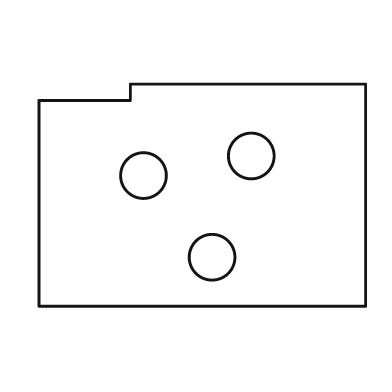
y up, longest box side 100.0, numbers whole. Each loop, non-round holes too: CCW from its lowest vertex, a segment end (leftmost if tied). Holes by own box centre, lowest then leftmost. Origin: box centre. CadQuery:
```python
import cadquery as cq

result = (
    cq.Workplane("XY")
    .moveTo(-50.0, -34.0)
    .lineTo(50.0, -34.0)
    .lineTo(50.0, 34.0)
    .lineTo(-22.0, 34.0)
    .lineTo(-22.0, 29.0)
    .lineTo(-50.0, 29.0)
    .close()
    .moveTo(3.0, -19.0)
    .circle(7.0)
    .moveTo(-18.0, 6.0)
    .circle(7.0)
    .moveTo(15.0, 12.0)
    .circle(7.0)
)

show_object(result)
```